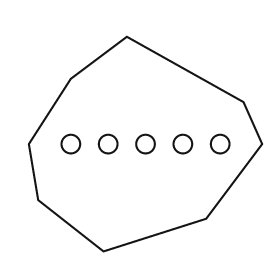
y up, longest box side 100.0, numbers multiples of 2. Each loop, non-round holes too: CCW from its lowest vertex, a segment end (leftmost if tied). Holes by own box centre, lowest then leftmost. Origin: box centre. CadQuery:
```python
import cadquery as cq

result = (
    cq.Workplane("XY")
    .moveTo(-18.0, -46.0)
    .lineTo(26.0, -32.0)
    .lineTo(50.0, 0.0)
    .lineTo(42.0, 18.0)
    .lineTo(-8.0, 46.0)
    .lineTo(-32.0, 28.0)
    .lineTo(-50.0, 0.0)
    .lineTo(-46.0, -24.0)
    .close()
    .moveTo(-32.0, 0.0)
    .circle(4.0)
    .moveTo(-16.0, 0.0)
    .circle(4.0)
    .moveTo(0.0, 0.0)
    .circle(4.0)
    .moveTo(16.0, 0.0)
    .circle(4.0)
    .moveTo(32.0, 0.0)
    .circle(4.0)
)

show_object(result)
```